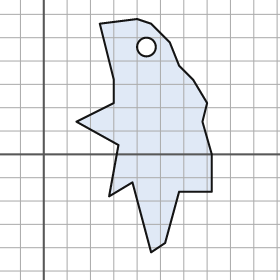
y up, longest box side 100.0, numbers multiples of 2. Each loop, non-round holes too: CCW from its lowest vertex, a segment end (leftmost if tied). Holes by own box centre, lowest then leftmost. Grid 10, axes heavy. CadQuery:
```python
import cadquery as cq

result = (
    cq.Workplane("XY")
    .moveTo(46.0, -42.0)
    .lineTo(52.0, -38.0)
    .lineTo(58.0, -16.0)
    .lineTo(72.0, -16.0)
    .lineTo(72.0, 0.0)
    .lineTo(68.0, 14.0)
    .lineTo(70.0, 22.0)
    .lineTo(64.0, 32.0)
    .lineTo(58.0, 38.0)
    .lineTo(54.0, 48.0)
    .lineTo(46.0, 56.0)
    .lineTo(40.0, 58.0)
    .lineTo(24.0, 56.0)
    .lineTo(30.0, 32.0)
    .lineTo(30.0, 22.0)
    .lineTo(14.0, 14.0)
    .lineTo(32.0, 4.0)
    .lineTo(28.0, -18.0)
    .lineTo(38.0, -12.0)
    .close()
    .moveTo(44.0, 46.0)
    .circle(4.0)
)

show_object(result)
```